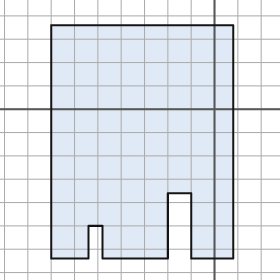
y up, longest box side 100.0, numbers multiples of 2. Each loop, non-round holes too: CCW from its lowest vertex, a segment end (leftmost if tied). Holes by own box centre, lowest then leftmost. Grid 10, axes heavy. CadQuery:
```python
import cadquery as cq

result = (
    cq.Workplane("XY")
    .moveTo(-70.0, -64.0)
    .lineTo(-54.0, -64.0)
    .lineTo(-54.0, -50.0)
    .lineTo(-48.0, -50.0)
    .lineTo(-48.0, -64.0)
    .lineTo(-20.0, -64.0)
    .lineTo(-20.0, -36.0)
    .lineTo(-10.0, -36.0)
    .lineTo(-10.0, -64.0)
    .lineTo(8.0, -64.0)
    .lineTo(8.0, 36.0)
    .lineTo(-70.0, 36.0)
    .close()
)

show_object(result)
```